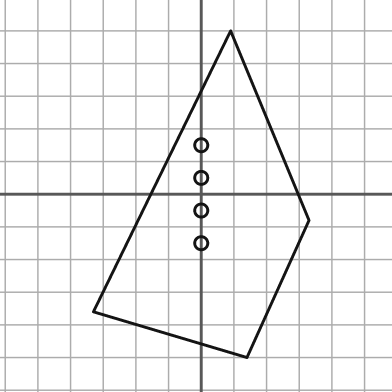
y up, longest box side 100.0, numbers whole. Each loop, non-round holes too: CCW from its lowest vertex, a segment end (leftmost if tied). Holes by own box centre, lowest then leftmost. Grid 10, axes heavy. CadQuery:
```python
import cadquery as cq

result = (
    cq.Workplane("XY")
    .moveTo(14.0, -50.0)
    .lineTo(33.0, -8.0)
    .lineTo(9.0, 50.0)
    .lineTo(-33.0, -36.0)
    .close()
    .moveTo(0.0, -15.0)
    .circle(2.0)
    .moveTo(0.0, -5.0)
    .circle(2.0)
    .moveTo(0.0, 5.0)
    .circle(2.0)
    .moveTo(0.0, 15.0)
    .circle(2.0)
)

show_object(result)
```